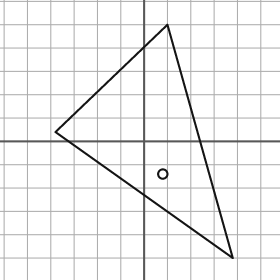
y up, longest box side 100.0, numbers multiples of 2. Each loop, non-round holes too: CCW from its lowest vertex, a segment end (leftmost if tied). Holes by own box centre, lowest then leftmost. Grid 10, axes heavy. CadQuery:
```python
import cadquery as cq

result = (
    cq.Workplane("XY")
    .moveTo(38.0, -50.0)
    .lineTo(10.0, 50.0)
    .lineTo(-38.0, 4.0)
    .close()
    .moveTo(8.0, -14.0)
    .circle(2.0)
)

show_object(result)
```